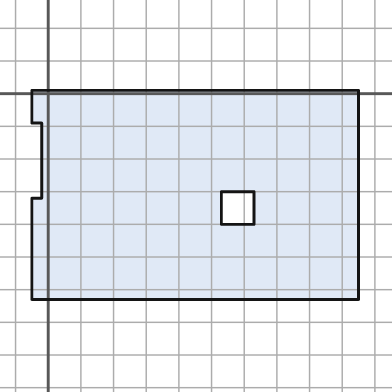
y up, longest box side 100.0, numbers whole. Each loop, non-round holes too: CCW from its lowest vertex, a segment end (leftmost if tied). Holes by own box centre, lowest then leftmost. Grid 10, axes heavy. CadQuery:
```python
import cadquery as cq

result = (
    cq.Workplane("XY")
    .moveTo(-5.0, -63.0)
    .lineTo(95.0, -63.0)
    .lineTo(95.0, 1.0)
    .lineTo(-5.0, 1.0)
    .lineTo(-5.0, -9.0)
    .lineTo(-2.0, -9.0)
    .lineTo(-2.0, -32.0)
    .lineTo(-5.0, -32.0)
    .close()
    .moveTo(53.0, -40.0)
    .lineTo(63.0, -40.0)
    .lineTo(63.0, -30.0)
    .lineTo(53.0, -30.0)
    .close()
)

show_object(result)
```